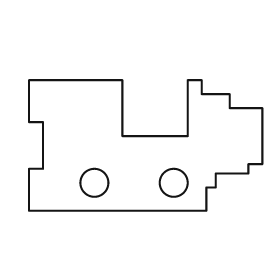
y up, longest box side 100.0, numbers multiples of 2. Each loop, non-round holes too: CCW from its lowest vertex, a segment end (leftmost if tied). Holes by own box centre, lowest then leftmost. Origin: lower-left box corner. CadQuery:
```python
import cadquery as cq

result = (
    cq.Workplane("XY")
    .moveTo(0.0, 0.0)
    .lineTo(76.0, 0.0)
    .lineTo(76.0, 10.0)
    .lineTo(80.0, 10.0)
    .lineTo(80.0, 16.0)
    .lineTo(94.0, 16.0)
    .lineTo(94.0, 20.0)
    .lineTo(100.0, 20.0)
    .lineTo(100.0, 44.0)
    .lineTo(86.0, 44.0)
    .lineTo(86.0, 50.0)
    .lineTo(74.0, 50.0)
    .lineTo(74.0, 56.0)
    .lineTo(68.0, 56.0)
    .lineTo(68.0, 32.0)
    .lineTo(40.0, 32.0)
    .lineTo(40.0, 56.0)
    .lineTo(0.0, 56.0)
    .lineTo(0.0, 38.0)
    .lineTo(6.0, 38.0)
    .lineTo(6.0, 18.0)
    .lineTo(0.0, 18.0)
    .close()
    .moveTo(28.0, 12.0)
    .circle(6.0)
    .moveTo(62.0, 12.0)
    .circle(6.0)
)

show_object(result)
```